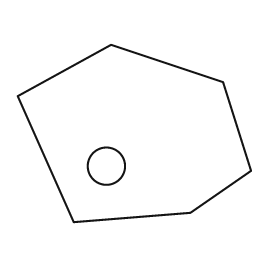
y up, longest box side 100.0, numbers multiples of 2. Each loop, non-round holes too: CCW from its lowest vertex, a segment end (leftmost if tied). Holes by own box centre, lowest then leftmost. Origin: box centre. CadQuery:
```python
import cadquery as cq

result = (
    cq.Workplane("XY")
    .moveTo(-26.0, -38.0)
    .lineTo(24.0, -34.0)
    .lineTo(50.0, -16.0)
    .lineTo(38.0, 22.0)
    .lineTo(-10.0, 38.0)
    .lineTo(-50.0, 16.0)
    .close()
    .moveTo(-12.0, -14.0)
    .circle(8.0)
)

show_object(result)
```